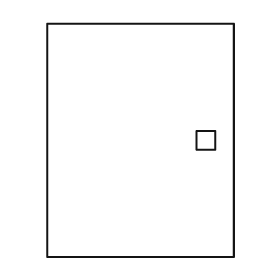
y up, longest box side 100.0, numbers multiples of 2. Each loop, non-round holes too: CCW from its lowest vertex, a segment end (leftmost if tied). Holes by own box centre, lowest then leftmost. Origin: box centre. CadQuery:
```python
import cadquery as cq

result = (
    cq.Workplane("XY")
    .moveTo(-40.0, -50.0)
    .lineTo(40.0, -50.0)
    .lineTo(40.0, 50.0)
    .lineTo(-40.0, 50.0)
    .close()
    .moveTo(24.0, -4.0)
    .lineTo(32.0, -4.0)
    .lineTo(32.0, 4.0)
    .lineTo(24.0, 4.0)
    .close()
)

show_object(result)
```